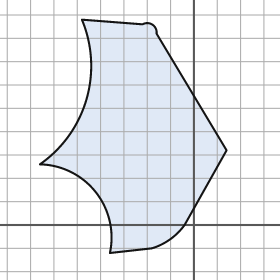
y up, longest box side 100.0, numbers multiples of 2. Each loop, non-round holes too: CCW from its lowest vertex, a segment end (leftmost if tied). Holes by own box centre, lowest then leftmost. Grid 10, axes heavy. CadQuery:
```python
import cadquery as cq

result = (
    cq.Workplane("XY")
    .moveTo(-36.0, -12.0)
    .lineTo(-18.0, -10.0)
    .threePointArc((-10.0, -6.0), (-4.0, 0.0))
    .lineTo(14.0, 32.0)
    .lineTo(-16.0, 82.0)
    .threePointArc((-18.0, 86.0), (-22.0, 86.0))
    .lineTo(-48.0, 88.0)
    .threePointArc((-46.0, 54.0), (-66.0, 26.0))
    .threePointArc((-42.0, 14.0), (-36.0, -12.0))
    .close()
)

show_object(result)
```